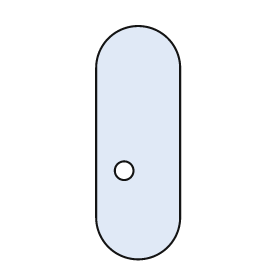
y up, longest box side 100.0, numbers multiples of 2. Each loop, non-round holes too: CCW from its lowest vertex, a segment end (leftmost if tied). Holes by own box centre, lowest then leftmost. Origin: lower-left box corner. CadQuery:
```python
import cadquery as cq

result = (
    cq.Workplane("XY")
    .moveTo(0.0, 18.0)
    .threePointArc((18.0, 0.0), (36.0, 18.0))
    .lineTo(36.0, 82.0)
    .threePointArc((18.0, 100.0), (0.0, 82.0))
    .close()
    .moveTo(12.0, 38.0)
    .circle(4.0)
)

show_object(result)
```